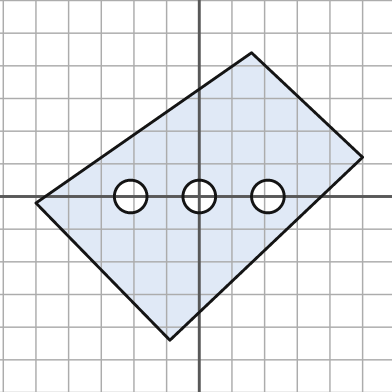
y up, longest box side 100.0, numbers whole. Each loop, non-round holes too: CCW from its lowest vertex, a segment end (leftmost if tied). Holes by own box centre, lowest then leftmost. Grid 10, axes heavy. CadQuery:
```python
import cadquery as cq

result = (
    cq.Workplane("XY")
    .moveTo(-9.0, -44.0)
    .lineTo(50.0, 12.0)
    .lineTo(16.0, 44.0)
    .lineTo(-50.0, -2.0)
    .close()
    .moveTo(-21.0, 0.0)
    .circle(5.0)
    .moveTo(0.0, 0.0)
    .circle(5.0)
    .moveTo(21.0, 0.0)
    .circle(5.0)
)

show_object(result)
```